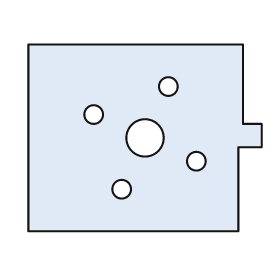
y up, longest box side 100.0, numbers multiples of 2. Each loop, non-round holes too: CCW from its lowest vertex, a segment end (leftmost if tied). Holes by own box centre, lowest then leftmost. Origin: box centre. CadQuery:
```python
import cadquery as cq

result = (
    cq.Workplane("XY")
    .moveTo(-50.0, -40.0)
    .lineTo(40.0, -40.0)
    .lineTo(40.0, -4.0)
    .lineTo(50.0, -4.0)
    .lineTo(50.0, 6.0)
    .lineTo(42.0, 6.0)
    .lineTo(42.0, 40.0)
    .lineTo(-50.0, 40.0)
    .close()
    .moveTo(-10.0, -22.0)
    .circle(4.0)
    .moveTo(22.0, -10.0)
    .circle(4.0)
    .moveTo(0.0, 0.0)
    .circle(8.0)
    .moveTo(-22.0, 10.0)
    .circle(4.0)
    .moveTo(10.0, 22.0)
    .circle(4.0)
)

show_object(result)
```